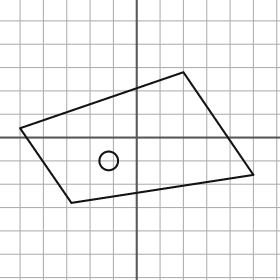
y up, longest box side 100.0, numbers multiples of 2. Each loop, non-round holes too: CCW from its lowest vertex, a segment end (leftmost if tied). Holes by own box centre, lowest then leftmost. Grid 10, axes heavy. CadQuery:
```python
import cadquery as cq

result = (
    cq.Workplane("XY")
    .moveTo(-28.0, -28.0)
    .lineTo(50.0, -16.0)
    .lineTo(20.0, 28.0)
    .lineTo(-50.0, 4.0)
    .close()
    .moveTo(-12.0, -10.0)
    .circle(4.0)
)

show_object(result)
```